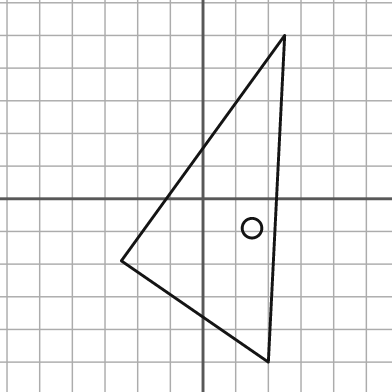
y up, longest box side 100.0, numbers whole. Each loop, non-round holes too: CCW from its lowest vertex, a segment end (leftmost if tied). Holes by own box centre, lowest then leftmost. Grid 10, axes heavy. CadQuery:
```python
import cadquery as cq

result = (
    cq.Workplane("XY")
    .moveTo(20.0, -50.0)
    .lineTo(25.0, 50.0)
    .lineTo(-25.0, -19.0)
    .close()
    .moveTo(15.0, -9.0)
    .circle(3.0)
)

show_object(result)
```